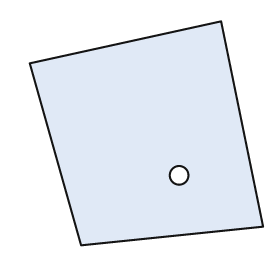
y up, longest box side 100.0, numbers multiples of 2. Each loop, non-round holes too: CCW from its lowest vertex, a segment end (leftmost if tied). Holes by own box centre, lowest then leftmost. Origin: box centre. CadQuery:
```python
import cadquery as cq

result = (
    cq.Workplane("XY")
    .moveTo(-28.0, -48.0)
    .lineTo(50.0, -40.0)
    .lineTo(32.0, 48.0)
    .lineTo(-50.0, 30.0)
    .close()
    .moveTo(14.0, -18.0)
    .circle(4.0)
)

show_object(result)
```